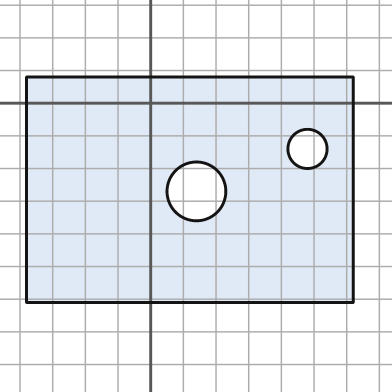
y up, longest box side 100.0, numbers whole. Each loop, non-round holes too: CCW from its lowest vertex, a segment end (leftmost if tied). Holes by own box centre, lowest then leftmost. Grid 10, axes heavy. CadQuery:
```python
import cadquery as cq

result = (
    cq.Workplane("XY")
    .moveTo(-38.0, -61.0)
    .lineTo(62.0, -61.0)
    .lineTo(62.0, 8.0)
    .lineTo(-38.0, 8.0)
    .close()
    .moveTo(14.0, -27.0)
    .circle(9.0)
    .moveTo(48.0, -14.0)
    .circle(6.0)
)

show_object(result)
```